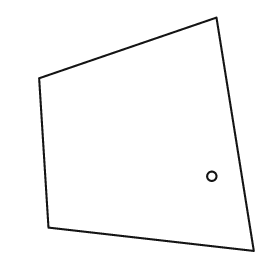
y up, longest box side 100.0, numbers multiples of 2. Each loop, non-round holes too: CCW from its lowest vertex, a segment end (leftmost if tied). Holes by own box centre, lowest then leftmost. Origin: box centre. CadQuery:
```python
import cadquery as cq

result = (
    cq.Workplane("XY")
    .moveTo(46.0, -50.0)
    .lineTo(30.0, 50.0)
    .lineTo(-46.0, 24.0)
    .lineTo(-42.0, -40.0)
    .close()
    .moveTo(28.0, -18.0)
    .circle(2.0)
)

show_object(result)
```